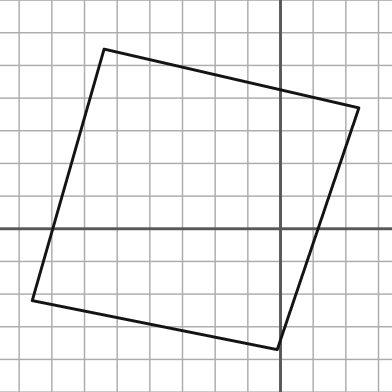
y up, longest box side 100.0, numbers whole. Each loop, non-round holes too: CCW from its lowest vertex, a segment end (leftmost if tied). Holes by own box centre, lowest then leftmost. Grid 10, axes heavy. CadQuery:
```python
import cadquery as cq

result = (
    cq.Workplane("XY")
    .moveTo(-1.0, -37.0)
    .lineTo(24.0, 37.0)
    .lineTo(-54.0, 55.0)
    .lineTo(-76.0, -22.0)
    .close()
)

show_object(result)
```